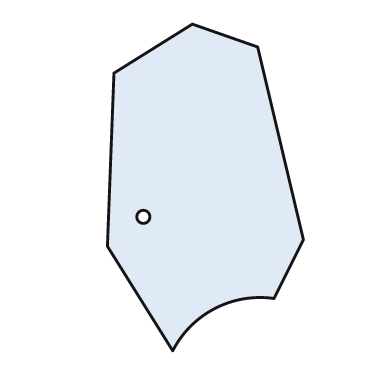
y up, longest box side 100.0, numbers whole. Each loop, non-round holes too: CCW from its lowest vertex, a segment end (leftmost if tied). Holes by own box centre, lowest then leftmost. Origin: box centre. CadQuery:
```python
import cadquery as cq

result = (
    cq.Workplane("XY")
    .moveTo(-10.0, -50.0)
    .threePointArc((3.0, -37.0), (21.0, -34.0))
    .lineTo(30.0, -16.0)
    .lineTo(16.0, 43.0)
    .lineTo(-4.0, 50.0)
    .lineTo(-28.0, 35.0)
    .lineTo(-30.0, -18.0)
    .close()
    .moveTo(-19.0, -9.0)
    .circle(2.0)
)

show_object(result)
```